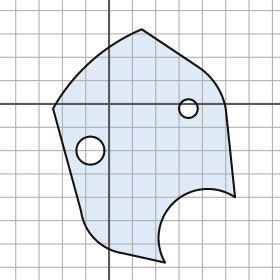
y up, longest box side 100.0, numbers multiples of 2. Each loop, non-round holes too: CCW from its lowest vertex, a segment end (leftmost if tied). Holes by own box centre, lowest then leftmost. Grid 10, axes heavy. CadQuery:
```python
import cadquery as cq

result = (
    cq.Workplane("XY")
    .moveTo(24.0, -68.0)
    .threePointArc((28.0, -42.0), (54.0, -40.0))
    .lineTo(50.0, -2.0)
    .threePointArc((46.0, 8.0), (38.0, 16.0))
    .lineTo(14.0, 32.0)
    .threePointArc((-8.0, 18.0), (-24.0, -2.0))
    .lineTo(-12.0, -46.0)
    .threePointArc((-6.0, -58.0), (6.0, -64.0))
    .close()
    .moveTo(-8.0, -20.0)
    .circle(6.0)
    .moveTo(34.0, -2.0)
    .circle(4.0)
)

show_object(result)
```